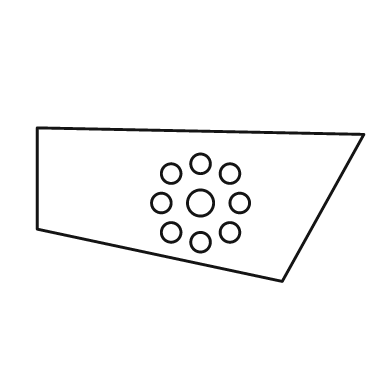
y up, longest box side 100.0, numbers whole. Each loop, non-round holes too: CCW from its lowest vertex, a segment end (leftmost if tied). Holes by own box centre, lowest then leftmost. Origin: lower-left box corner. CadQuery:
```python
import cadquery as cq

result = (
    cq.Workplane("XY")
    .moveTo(75.0, 0.0)
    .lineTo(100.0, 45.0)
    .lineTo(0.0, 47.0)
    .lineTo(0.0, 16.0)
    .close()
    .moveTo(50.0, 12.0)
    .circle(3.0)
    .moveTo(41.0, 15.0)
    .circle(3.0)
    .moveTo(59.0, 15.0)
    .circle(3.0)
    .moveTo(38.0, 24.0)
    .circle(3.0)
    .moveTo(50.0, 24.0)
    .circle(4.0)
    .moveTo(62.0, 24.0)
    .circle(3.0)
    .moveTo(41.0, 33.0)
    .circle(3.0)
    .moveTo(59.0, 33.0)
    .circle(3.0)
    .moveTo(50.0, 36.0)
    .circle(3.0)
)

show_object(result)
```